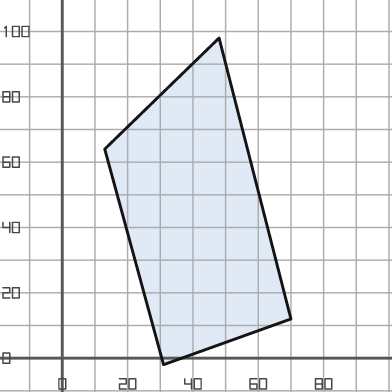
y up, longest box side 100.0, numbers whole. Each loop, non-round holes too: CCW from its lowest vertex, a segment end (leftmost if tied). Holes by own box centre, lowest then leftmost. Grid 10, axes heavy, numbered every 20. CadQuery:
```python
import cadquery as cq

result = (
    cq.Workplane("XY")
    .moveTo(31.0, -2.0)
    .lineTo(70.0, 12.0)
    .lineTo(48.0, 98.0)
    .lineTo(13.0, 64.0)
    .close()
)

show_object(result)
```